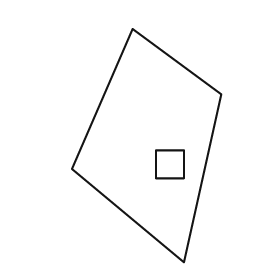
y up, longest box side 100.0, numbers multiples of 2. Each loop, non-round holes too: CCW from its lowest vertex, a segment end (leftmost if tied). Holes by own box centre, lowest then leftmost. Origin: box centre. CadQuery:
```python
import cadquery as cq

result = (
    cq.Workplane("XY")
    .moveTo(16.0, -50.0)
    .lineTo(32.0, 22.0)
    .lineTo(-6.0, 50.0)
    .lineTo(-32.0, -10.0)
    .close()
    .moveTo(4.0, -14.0)
    .lineTo(16.0, -14.0)
    .lineTo(16.0, -2.0)
    .lineTo(4.0, -2.0)
    .close()
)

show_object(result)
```